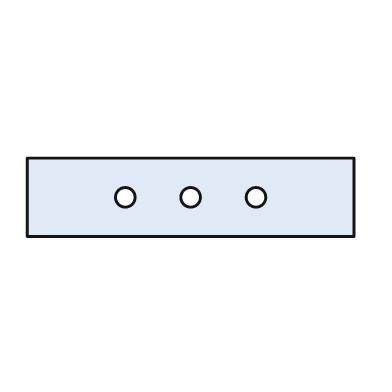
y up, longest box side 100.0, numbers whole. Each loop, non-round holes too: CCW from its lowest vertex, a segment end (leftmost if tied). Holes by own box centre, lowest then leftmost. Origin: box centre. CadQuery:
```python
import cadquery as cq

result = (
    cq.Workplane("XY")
    .moveTo(-50.0, -12.0)
    .lineTo(50.0, -12.0)
    .lineTo(50.0, 12.0)
    .lineTo(-50.0, 12.0)
    .close()
    .moveTo(-20.0, 0.0)
    .circle(3.0)
    .moveTo(0.0, 0.0)
    .circle(3.0)
    .moveTo(20.0, 0.0)
    .circle(3.0)
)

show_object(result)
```